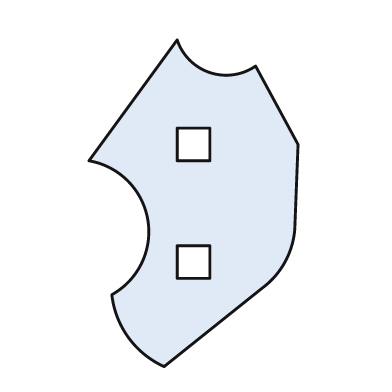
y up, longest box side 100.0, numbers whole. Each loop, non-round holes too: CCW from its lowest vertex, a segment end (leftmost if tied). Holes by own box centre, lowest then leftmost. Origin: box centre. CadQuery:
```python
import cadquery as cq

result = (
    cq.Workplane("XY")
    .moveTo(-9.0, -50.0)
    .lineTo(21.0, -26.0)
    .threePointArc((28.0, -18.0), (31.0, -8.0))
    .lineTo(32.0, 18.0)
    .lineTo(19.0, 42.0)
    .threePointArc((5.0, 40.0), (-5.0, 50.0))
    .lineTo(-32.0, 13.0)
    .threePointArc((-14.0, -5.0), (-25.0, -28.0))
    .threePointArc((-20.0, -41.0), (-9.0, -50.0))
    .close()
    .moveTo(-5.0, -23.0)
    .lineTo(5.0, -23.0)
    .lineTo(5.0, -13.0)
    .lineTo(-5.0, -13.0)
    .close()
    .moveTo(-5.0, 13.0)
    .lineTo(5.0, 13.0)
    .lineTo(5.0, 23.0)
    .lineTo(-5.0, 23.0)
    .close()
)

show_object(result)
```